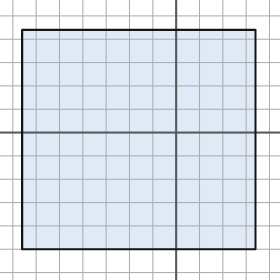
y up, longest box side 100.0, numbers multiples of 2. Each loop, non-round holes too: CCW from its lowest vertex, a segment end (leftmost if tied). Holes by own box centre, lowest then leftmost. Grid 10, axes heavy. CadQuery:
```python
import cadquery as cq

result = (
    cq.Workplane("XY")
    .moveTo(-66.0, -50.0)
    .lineTo(34.0, -50.0)
    .lineTo(34.0, 44.0)
    .lineTo(-66.0, 44.0)
    .close()
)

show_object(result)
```